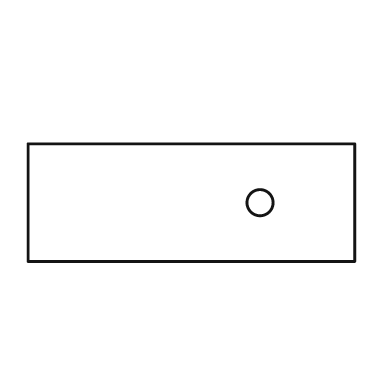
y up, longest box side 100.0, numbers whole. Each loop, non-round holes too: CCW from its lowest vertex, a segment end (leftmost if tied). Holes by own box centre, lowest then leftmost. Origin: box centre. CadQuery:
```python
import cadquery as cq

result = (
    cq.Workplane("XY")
    .moveTo(-50.0, -18.0)
    .lineTo(50.0, -18.0)
    .lineTo(50.0, 18.0)
    .lineTo(-50.0, 18.0)
    .close()
    .moveTo(21.0, 0.0)
    .circle(4.0)
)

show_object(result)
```